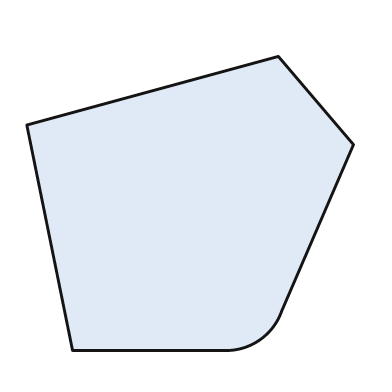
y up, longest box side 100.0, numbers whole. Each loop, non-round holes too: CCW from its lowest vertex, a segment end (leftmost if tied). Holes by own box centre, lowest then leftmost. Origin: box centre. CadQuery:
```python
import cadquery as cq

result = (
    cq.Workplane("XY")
    .moveTo(-36.0, -45.0)
    .lineTo(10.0, -45.0)
    .threePointArc((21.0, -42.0), (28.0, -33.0))
    .lineTo(50.0, 18.0)
    .lineTo(27.0, 45.0)
    .lineTo(-50.0, 24.0)
    .close()
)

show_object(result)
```